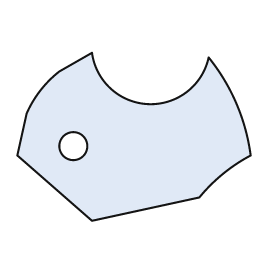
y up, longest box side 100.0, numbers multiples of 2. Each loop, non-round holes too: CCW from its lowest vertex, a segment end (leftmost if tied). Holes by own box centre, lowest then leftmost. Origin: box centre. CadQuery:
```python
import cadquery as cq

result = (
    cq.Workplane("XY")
    .moveTo(-18.0, -36.0)
    .lineTo(28.0, -26.0)
    .threePointArc((38.0, -16.0), (50.0, -8.0))
    .threePointArc((44.0, 14.0), (32.0, 34.0))
    .threePointArc((6.0, 14.0), (-18.0, 36.0))
    .lineTo(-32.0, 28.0)
    .threePointArc((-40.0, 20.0), (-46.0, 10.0))
    .lineTo(-50.0, -8.0)
    .close()
    .moveTo(-26.0, -4.0)
    .circle(6.0)
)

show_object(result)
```